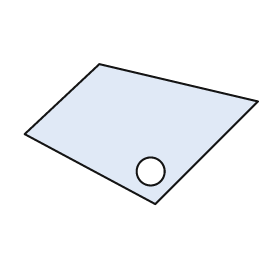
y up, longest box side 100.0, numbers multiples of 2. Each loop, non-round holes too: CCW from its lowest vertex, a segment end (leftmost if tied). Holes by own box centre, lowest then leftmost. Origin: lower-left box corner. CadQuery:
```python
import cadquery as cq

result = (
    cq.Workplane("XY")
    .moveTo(56.0, 0.0)
    .lineTo(100.0, 44.0)
    .lineTo(32.0, 60.0)
    .lineTo(0.0, 30.0)
    .close()
    .moveTo(54.0, 14.0)
    .circle(6.0)
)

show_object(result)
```